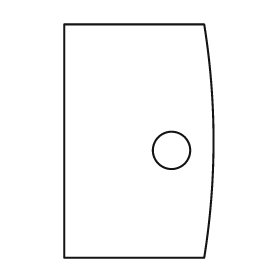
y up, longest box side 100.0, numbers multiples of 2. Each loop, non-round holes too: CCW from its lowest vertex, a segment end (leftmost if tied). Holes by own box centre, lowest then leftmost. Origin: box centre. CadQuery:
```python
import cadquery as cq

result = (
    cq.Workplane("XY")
    .moveTo(-32.0, -50.0)
    .lineTo(28.0, -50.0)
    .threePointArc((32.0, 0.0), (28.0, 50.0))
    .lineTo(-32.0, 50.0)
    .close()
    .moveTo(14.0, -4.0)
    .circle(8.0)
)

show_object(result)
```